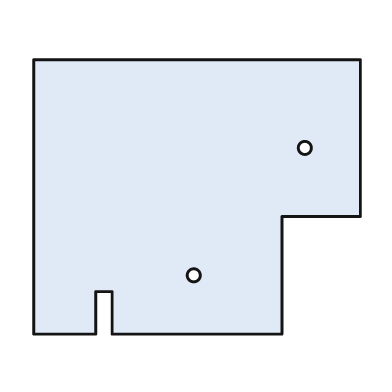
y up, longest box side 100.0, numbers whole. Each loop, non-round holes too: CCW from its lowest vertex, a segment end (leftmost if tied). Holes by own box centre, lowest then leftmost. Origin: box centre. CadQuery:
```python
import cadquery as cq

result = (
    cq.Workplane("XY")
    .moveTo(-50.0, -42.0)
    .lineTo(-31.0, -42.0)
    .lineTo(-31.0, -29.0)
    .lineTo(-26.0, -29.0)
    .lineTo(-26.0, -42.0)
    .lineTo(26.0, -42.0)
    .lineTo(26.0, -6.0)
    .lineTo(50.0, -6.0)
    .lineTo(50.0, 42.0)
    .lineTo(-50.0, 42.0)
    .close()
    .moveTo(-1.0, -24.0)
    .circle(2.0)
    .moveTo(33.0, 15.0)
    .circle(2.0)
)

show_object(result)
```